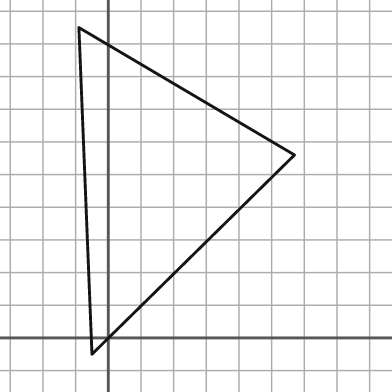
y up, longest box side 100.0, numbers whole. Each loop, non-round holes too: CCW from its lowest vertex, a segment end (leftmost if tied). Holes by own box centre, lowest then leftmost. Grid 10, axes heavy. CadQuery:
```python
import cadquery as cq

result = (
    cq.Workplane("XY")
    .moveTo(-5.0, -5.0)
    .lineTo(57.0, 56.0)
    .lineTo(-9.0, 95.0)
    .close()
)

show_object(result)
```